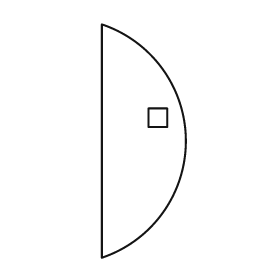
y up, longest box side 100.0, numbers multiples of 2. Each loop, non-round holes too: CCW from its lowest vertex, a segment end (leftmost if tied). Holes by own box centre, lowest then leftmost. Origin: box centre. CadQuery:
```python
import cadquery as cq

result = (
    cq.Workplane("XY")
    .moveTo(-18.0, -50.0)
    .threePointArc((18.0, 0.0), (-18.0, 50.0))
    .close()
    .moveTo(2.0, 6.0)
    .lineTo(10.0, 6.0)
    .lineTo(10.0, 14.0)
    .lineTo(2.0, 14.0)
    .close()
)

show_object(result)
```